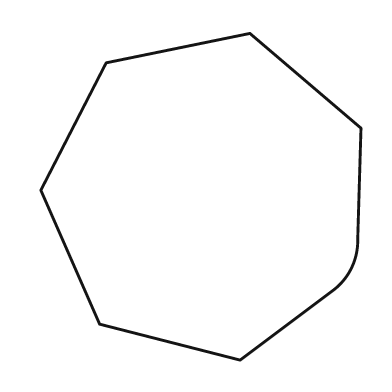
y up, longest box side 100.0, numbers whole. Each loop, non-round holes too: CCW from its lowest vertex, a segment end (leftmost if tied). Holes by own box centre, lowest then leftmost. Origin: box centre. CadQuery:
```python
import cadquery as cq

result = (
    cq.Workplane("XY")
    .moveTo(12.0, -50.0)
    .lineTo(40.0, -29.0)
    .threePointArc((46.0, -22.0), (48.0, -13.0))
    .lineTo(49.0, 21.0)
    .lineTo(15.0, 50.0)
    .lineTo(-29.0, 41.0)
    .lineTo(-49.0, 2.0)
    .lineTo(-31.0, -39.0)
    .close()
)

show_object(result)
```